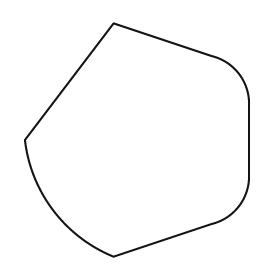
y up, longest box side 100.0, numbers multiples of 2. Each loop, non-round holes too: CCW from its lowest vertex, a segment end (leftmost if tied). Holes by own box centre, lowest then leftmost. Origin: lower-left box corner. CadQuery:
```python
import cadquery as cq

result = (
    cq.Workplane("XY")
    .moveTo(38.0, 0.0)
    .lineTo(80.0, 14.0)
    .threePointArc((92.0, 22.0), (96.0, 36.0))
    .lineTo(96.0, 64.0)
    .threePointArc((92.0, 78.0), (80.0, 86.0))
    .lineTo(38.0, 100.0)
    .lineTo(0.0, 50.0)
    .threePointArc((12.0, 20.0), (38.0, 0.0))
    .close()
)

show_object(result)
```